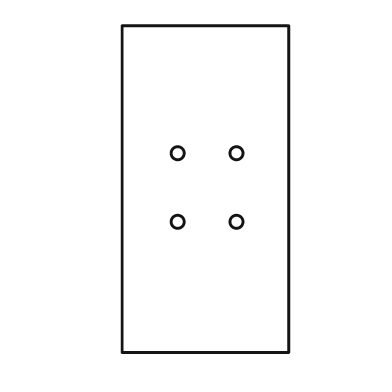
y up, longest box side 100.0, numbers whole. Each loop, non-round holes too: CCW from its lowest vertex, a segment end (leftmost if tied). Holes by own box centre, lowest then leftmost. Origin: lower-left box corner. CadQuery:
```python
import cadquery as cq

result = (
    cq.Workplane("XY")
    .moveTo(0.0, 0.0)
    .lineTo(51.0, 0.0)
    .lineTo(51.0, 100.0)
    .lineTo(0.0, 100.0)
    .close()
    .moveTo(17.0, 40.0)
    .circle(2.0)
    .moveTo(35.0, 40.0)
    .circle(2.0)
    .moveTo(17.0, 61.0)
    .circle(2.0)
    .moveTo(35.0, 61.0)
    .circle(2.0)
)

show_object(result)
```